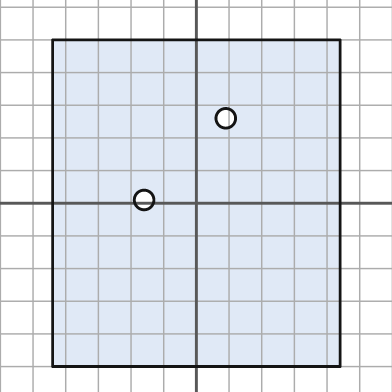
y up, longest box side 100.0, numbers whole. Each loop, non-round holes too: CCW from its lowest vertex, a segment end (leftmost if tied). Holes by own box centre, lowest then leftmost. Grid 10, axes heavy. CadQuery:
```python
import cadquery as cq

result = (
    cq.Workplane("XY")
    .moveTo(-44.0, -50.0)
    .lineTo(44.0, -50.0)
    .lineTo(44.0, 50.0)
    .lineTo(-44.0, 50.0)
    .close()
    .moveTo(-16.0, 1.0)
    .circle(3.0)
    .moveTo(9.0, 26.0)
    .circle(3.0)
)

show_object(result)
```